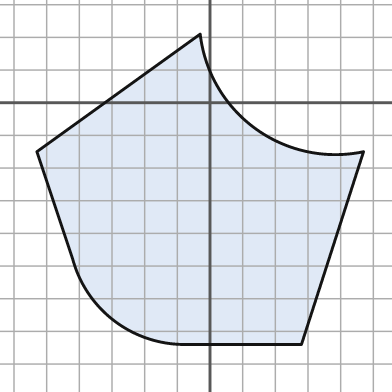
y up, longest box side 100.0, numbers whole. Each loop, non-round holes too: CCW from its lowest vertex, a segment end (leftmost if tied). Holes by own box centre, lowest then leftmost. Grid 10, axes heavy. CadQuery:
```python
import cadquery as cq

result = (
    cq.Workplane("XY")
    .moveTo(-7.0, -74.0)
    .lineTo(28.0, -74.0)
    .lineTo(47.0, -15.0)
    .threePointArc((14.0, -8.0), (-3.0, 21.0))
    .lineTo(-53.0, -15.0)
    .lineTo(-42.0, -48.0)
    .threePointArc((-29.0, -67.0), (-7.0, -74.0))
    .close()
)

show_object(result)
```